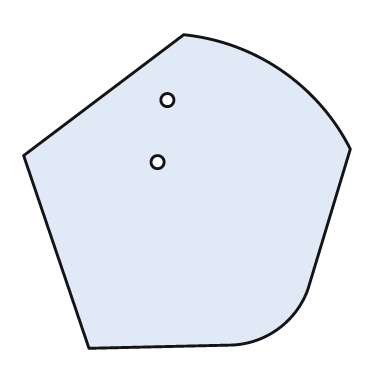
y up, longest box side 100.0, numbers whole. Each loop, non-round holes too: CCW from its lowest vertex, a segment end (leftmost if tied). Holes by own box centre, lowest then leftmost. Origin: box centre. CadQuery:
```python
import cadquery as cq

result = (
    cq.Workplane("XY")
    .moveTo(-30.0, -48.0)
    .lineTo(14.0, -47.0)
    .threePointArc((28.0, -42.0), (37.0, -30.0))
    .lineTo(50.0, 13.0)
    .threePointArc((29.0, 37.0), (-1.0, 48.0))
    .lineTo(-50.0, 11.0)
    .close()
    .moveTo(-9.0, 9.0)
    .circle(2.0)
    .moveTo(-6.0, 28.0)
    .circle(2.0)
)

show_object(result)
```